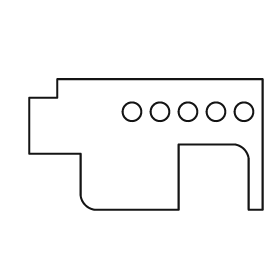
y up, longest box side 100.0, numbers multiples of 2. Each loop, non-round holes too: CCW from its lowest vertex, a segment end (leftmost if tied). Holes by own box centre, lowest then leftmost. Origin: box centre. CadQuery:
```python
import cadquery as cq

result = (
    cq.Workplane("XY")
    .moveTo(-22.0, -28.0)
    .lineTo(14.0, -28.0)
    .lineTo(14.0, 0.0)
    .lineTo(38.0, 0.0)
    .threePointArc((42.0, -2.0), (44.0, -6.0))
    .lineTo(44.0, -28.0)
    .lineTo(50.0, -28.0)
    .lineTo(50.0, 28.0)
    .lineTo(-38.0, 28.0)
    .lineTo(-38.0, 20.0)
    .lineTo(-50.0, 20.0)
    .lineTo(-50.0, -4.0)
    .lineTo(-28.0, -4.0)
    .lineTo(-28.0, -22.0)
    .threePointArc((-26.0, -26.0), (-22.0, -28.0))
    .close()
    .moveTo(-6.0, 14.0)
    .circle(4.0)
    .moveTo(6.0, 14.0)
    .circle(4.0)
    .moveTo(18.0, 14.0)
    .circle(4.0)
    .moveTo(30.0, 14.0)
    .circle(4.0)
    .moveTo(42.0, 14.0)
    .circle(4.0)
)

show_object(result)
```